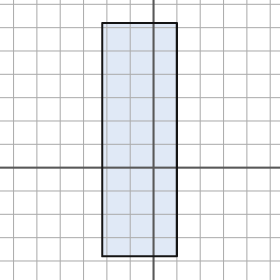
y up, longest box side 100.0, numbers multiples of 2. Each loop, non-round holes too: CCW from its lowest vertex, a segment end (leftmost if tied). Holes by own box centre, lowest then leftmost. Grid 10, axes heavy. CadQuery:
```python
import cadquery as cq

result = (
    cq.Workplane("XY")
    .moveTo(-22.0, -38.0)
    .lineTo(10.0, -38.0)
    .lineTo(10.0, 62.0)
    .lineTo(-22.0, 62.0)
    .close()
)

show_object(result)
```